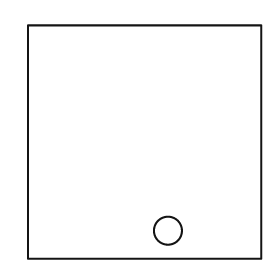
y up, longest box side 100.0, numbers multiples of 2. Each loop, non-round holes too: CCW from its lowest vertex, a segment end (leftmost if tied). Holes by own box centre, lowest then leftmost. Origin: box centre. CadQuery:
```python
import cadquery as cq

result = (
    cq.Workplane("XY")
    .moveTo(-50.0, -50.0)
    .lineTo(50.0, -50.0)
    .lineTo(50.0, 50.0)
    .lineTo(-50.0, 50.0)
    .close()
    .moveTo(10.0, -38.0)
    .circle(6.0)
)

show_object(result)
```